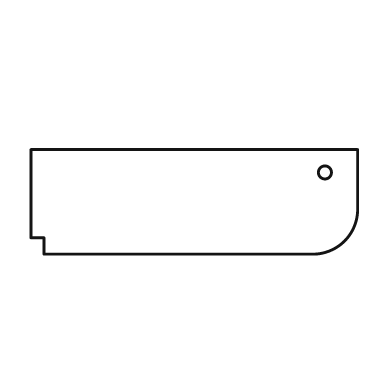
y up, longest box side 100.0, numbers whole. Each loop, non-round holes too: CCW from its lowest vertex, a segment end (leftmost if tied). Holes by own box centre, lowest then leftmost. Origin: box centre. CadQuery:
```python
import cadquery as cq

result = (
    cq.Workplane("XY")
    .moveTo(-46.0, -16.0)
    .lineTo(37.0, -16.0)
    .threePointArc((46.0, -12.0), (50.0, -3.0))
    .lineTo(50.0, 16.0)
    .lineTo(-50.0, 16.0)
    .lineTo(-50.0, -11.0)
    .lineTo(-46.0, -11.0)
    .close()
    .moveTo(40.0, 9.0)
    .circle(2.0)
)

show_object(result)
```